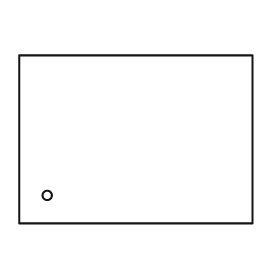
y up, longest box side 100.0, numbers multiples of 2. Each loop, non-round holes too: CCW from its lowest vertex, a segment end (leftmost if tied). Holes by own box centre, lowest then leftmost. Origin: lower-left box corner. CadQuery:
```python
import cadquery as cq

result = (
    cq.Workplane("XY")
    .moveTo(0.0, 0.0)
    .lineTo(100.0, 0.0)
    .lineTo(100.0, 72.0)
    .lineTo(0.0, 72.0)
    .close()
    .moveTo(12.0, 12.0)
    .circle(2.0)
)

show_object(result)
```